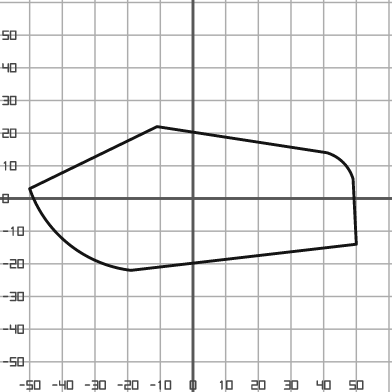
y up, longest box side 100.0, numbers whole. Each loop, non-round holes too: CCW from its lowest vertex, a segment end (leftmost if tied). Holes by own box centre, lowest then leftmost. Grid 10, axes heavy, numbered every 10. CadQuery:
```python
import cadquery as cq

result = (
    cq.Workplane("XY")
    .moveTo(-19.0, -22.0)
    .lineTo(50.0, -14.0)
    .lineTo(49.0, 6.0)
    .threePointArc((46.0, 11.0), (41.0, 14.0))
    .lineTo(-11.0, 22.0)
    .lineTo(-50.0, 3.0)
    .threePointArc((-38.0, -14.0), (-19.0, -22.0))
    .close()
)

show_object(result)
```